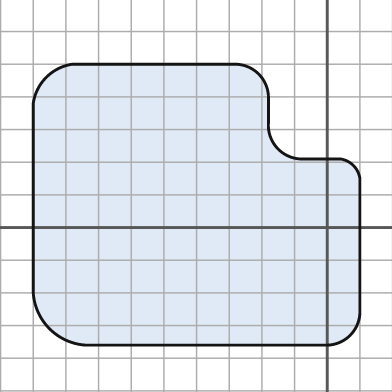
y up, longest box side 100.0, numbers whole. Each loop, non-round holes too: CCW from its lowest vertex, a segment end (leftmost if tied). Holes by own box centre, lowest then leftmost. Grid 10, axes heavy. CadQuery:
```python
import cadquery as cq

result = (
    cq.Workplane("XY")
    .moveTo(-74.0, -36.0)
    .lineTo(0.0, -36.0)
    .threePointArc((7.0, -33.0), (10.0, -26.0))
    .lineTo(10.0, 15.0)
    .threePointArc((8.0, 19.0), (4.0, 21.0))
    .lineTo(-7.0, 21.0)
    .threePointArc((-15.0, 24.0), (-18.0, 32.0))
    .lineTo(-18.0, 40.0)
    .threePointArc((-21.0, 47.0), (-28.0, 50.0))
    .lineTo(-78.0, 50.0)
    .threePointArc((-86.0, 46.0), (-90.0, 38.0))
    .lineTo(-90.0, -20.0)
    .threePointArc((-85.0, -31.0), (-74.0, -36.0))
    .close()
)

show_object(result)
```